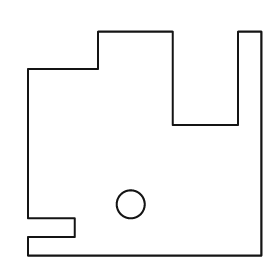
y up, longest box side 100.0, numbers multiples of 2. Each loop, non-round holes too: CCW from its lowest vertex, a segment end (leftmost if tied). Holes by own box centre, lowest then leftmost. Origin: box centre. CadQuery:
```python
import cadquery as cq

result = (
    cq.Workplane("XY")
    .moveTo(-50.0, -48.0)
    .lineTo(50.0, -48.0)
    .lineTo(50.0, 48.0)
    .lineTo(40.0, 48.0)
    .lineTo(40.0, 8.0)
    .lineTo(12.0, 8.0)
    .lineTo(12.0, 48.0)
    .lineTo(-20.0, 48.0)
    .lineTo(-20.0, 32.0)
    .lineTo(-50.0, 32.0)
    .lineTo(-50.0, -32.0)
    .lineTo(-30.0, -32.0)
    .lineTo(-30.0, -40.0)
    .lineTo(-50.0, -40.0)
    .close()
    .moveTo(-6.0, -26.0)
    .circle(6.0)
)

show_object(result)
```